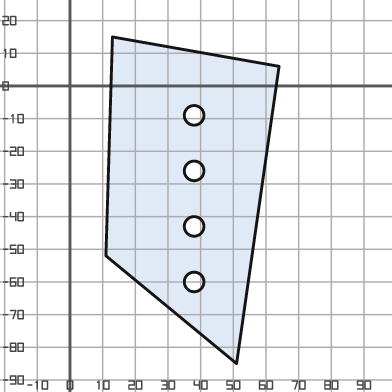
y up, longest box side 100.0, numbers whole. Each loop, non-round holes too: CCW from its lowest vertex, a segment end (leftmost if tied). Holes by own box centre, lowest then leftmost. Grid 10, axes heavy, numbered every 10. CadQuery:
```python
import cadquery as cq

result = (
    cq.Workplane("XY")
    .moveTo(51.0, -85.0)
    .lineTo(64.0, 6.0)
    .lineTo(13.0, 15.0)
    .lineTo(11.0, -52.0)
    .close()
    .moveTo(38.0, -60.0)
    .circle(3.0)
    .moveTo(38.0, -43.0)
    .circle(3.0)
    .moveTo(38.0, -26.0)
    .circle(3.0)
    .moveTo(38.0, -9.0)
    .circle(3.0)
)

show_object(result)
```